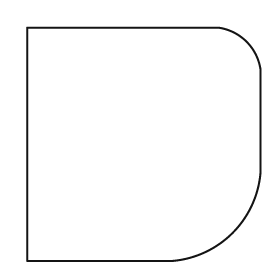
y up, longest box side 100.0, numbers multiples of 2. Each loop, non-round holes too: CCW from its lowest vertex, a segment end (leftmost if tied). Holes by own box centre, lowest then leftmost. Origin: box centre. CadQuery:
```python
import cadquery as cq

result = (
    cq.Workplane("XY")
    .moveTo(-50.0, -50.0)
    .lineTo(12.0, -50.0)
    .threePointArc((38.0, -38.0), (50.0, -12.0))
    .lineTo(50.0, 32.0)
    .threePointArc((44.0, 44.0), (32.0, 50.0))
    .lineTo(-50.0, 50.0)
    .close()
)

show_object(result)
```